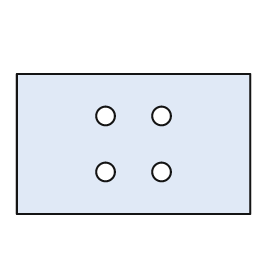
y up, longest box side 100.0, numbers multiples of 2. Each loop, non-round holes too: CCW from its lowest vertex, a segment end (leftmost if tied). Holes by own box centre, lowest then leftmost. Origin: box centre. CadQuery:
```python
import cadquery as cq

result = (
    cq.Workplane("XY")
    .moveTo(-50.0, -30.0)
    .lineTo(50.0, -30.0)
    .lineTo(50.0, 30.0)
    .lineTo(-50.0, 30.0)
    .close()
    .moveTo(-12.0, -12.0)
    .circle(4.0)
    .moveTo(12.0, -12.0)
    .circle(4.0)
    .moveTo(-12.0, 12.0)
    .circle(4.0)
    .moveTo(12.0, 12.0)
    .circle(4.0)
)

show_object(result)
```